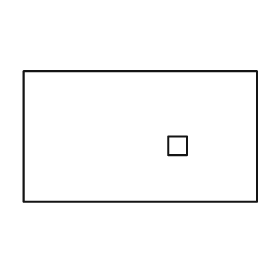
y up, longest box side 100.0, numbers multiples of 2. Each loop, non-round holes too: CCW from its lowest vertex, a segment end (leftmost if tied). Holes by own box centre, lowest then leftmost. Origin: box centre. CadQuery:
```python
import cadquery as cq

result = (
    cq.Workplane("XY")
    .moveTo(-50.0, -28.0)
    .lineTo(50.0, -28.0)
    .lineTo(50.0, 28.0)
    .lineTo(-50.0, 28.0)
    .close()
    .moveTo(12.0, -8.0)
    .lineTo(20.0, -8.0)
    .lineTo(20.0, 0.0)
    .lineTo(12.0, 0.0)
    .close()
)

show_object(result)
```